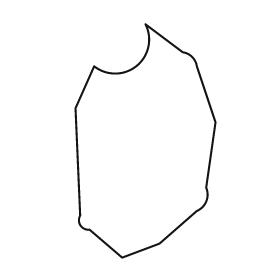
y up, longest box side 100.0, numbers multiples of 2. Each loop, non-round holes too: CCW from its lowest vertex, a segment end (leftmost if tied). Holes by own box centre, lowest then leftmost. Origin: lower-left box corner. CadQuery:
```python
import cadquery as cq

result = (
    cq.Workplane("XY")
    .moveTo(20.0, 0.0)
    .lineTo(36.0, 6.0)
    .lineTo(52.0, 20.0)
    .threePointArc((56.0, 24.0), (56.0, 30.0))
    .lineTo(60.0, 58.0)
    .lineTo(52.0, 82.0)
    .threePointArc((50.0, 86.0), (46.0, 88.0))
    .lineTo(30.0, 100.0)
    .threePointArc((26.0, 82.0), (8.0, 82.0))
    .lineTo(0.0, 64.0)
    .lineTo(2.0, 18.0)
    .threePointArc((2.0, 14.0), (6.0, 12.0))
    .close()
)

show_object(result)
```